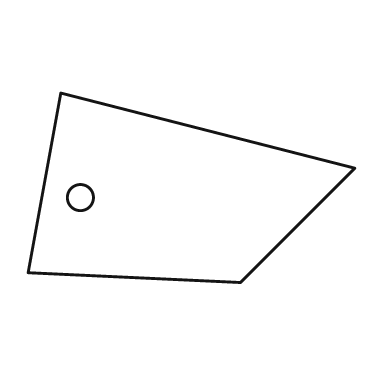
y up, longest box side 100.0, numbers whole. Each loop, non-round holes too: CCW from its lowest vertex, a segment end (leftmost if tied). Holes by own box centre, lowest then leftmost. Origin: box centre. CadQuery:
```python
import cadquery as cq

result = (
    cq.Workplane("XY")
    .moveTo(15.0, -29.0)
    .lineTo(50.0, 6.0)
    .lineTo(-40.0, 29.0)
    .lineTo(-50.0, -26.0)
    .close()
    .moveTo(-34.0, -3.0)
    .circle(4.0)
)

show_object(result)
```